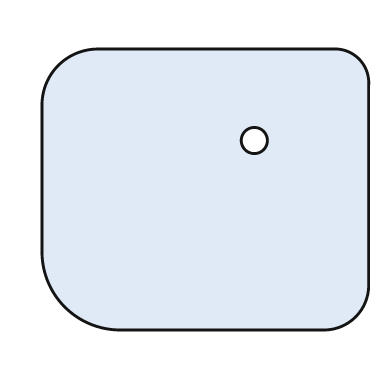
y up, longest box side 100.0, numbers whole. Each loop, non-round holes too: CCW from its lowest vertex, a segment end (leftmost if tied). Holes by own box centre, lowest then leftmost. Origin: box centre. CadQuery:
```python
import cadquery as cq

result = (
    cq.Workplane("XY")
    .moveTo(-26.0, -43.0)
    .lineTo(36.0, -43.0)
    .threePointArc((46.0, -39.0), (50.0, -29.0))
    .lineTo(50.0, 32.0)
    .threePointArc((47.0, 40.0), (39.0, 43.0))
    .lineTo(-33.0, 43.0)
    .threePointArc((-45.0, 38.0), (-50.0, 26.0))
    .lineTo(-50.0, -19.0)
    .threePointArc((-43.0, -36.0), (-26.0, -43.0))
    .close()
    .moveTo(15.0, 15.0)
    .circle(4.0)
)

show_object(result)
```